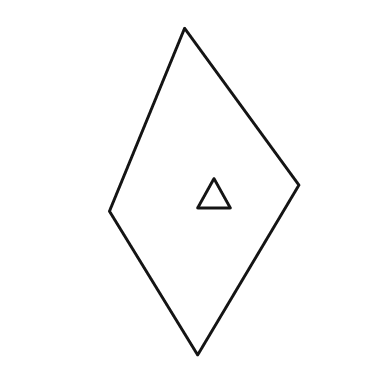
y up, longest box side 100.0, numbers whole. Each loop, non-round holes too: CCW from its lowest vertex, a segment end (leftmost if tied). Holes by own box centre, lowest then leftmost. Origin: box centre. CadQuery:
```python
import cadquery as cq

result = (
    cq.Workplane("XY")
    .moveTo(-2.0, -50.0)
    .lineTo(29.0, 2.0)
    .lineTo(-6.0, 50.0)
    .lineTo(-29.0, -6.0)
    .close()
    .moveTo(-2.0, -5.0)
    .lineTo(8.0, -5.0)
    .lineTo(3.0, 4.0)
    .close()
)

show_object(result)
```